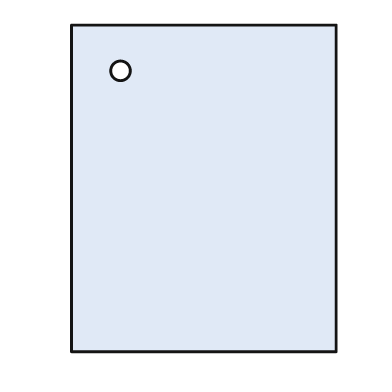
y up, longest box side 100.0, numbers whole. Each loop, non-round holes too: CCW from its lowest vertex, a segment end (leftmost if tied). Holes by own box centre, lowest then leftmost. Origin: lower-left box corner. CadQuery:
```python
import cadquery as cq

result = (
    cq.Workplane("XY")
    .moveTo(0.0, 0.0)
    .lineTo(81.0, 0.0)
    .lineTo(81.0, 100.0)
    .lineTo(0.0, 100.0)
    .close()
    .moveTo(15.0, 86.0)
    .circle(3.0)
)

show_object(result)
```